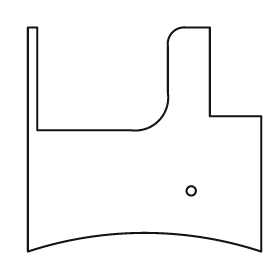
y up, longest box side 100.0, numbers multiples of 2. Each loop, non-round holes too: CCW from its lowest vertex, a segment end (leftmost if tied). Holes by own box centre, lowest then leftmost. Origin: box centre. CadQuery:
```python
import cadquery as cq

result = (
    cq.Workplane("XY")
    .moveTo(-50.0, -48.0)
    .threePointArc((0.0, -40.0), (50.0, -48.0))
    .lineTo(50.0, 10.0)
    .lineTo(28.0, 10.0)
    .lineTo(28.0, 48.0)
    .lineTo(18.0, 48.0)
    .threePointArc((12.0, 46.0), (10.0, 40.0))
    .lineTo(10.0, 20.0)
    .threePointArc((6.0, 8.0), (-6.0, 4.0))
    .lineTo(-46.0, 4.0)
    .lineTo(-46.0, 48.0)
    .lineTo(-50.0, 48.0)
    .close()
    .moveTo(20.0, -22.0)
    .circle(2.0)
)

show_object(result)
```